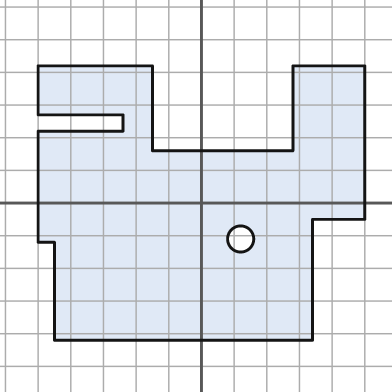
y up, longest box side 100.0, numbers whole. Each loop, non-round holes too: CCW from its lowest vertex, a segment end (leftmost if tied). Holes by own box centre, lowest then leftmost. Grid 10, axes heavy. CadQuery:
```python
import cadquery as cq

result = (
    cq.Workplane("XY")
    .moveTo(-45.0, -42.0)
    .lineTo(34.0, -42.0)
    .lineTo(34.0, -5.0)
    .lineTo(50.0, -5.0)
    .lineTo(50.0, 42.0)
    .lineTo(28.0, 42.0)
    .lineTo(28.0, 16.0)
    .lineTo(-15.0, 16.0)
    .lineTo(-15.0, 42.0)
    .lineTo(-50.0, 42.0)
    .lineTo(-50.0, 27.0)
    .lineTo(-24.0, 27.0)
    .lineTo(-24.0, 22.0)
    .lineTo(-50.0, 22.0)
    .lineTo(-50.0, -12.0)
    .lineTo(-45.0, -12.0)
    .close()
    .moveTo(12.0, -11.0)
    .circle(4.0)
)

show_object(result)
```